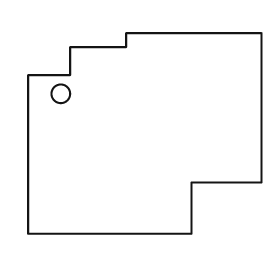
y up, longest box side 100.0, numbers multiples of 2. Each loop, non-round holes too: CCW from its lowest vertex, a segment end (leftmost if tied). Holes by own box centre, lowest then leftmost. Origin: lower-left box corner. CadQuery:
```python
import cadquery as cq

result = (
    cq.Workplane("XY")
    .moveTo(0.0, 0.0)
    .lineTo(70.0, 0.0)
    .lineTo(70.0, 22.0)
    .lineTo(100.0, 22.0)
    .lineTo(100.0, 86.0)
    .lineTo(42.0, 86.0)
    .lineTo(42.0, 80.0)
    .lineTo(18.0, 80.0)
    .lineTo(18.0, 68.0)
    .lineTo(0.0, 68.0)
    .close()
    .moveTo(14.0, 60.0)
    .circle(4.0)
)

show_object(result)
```